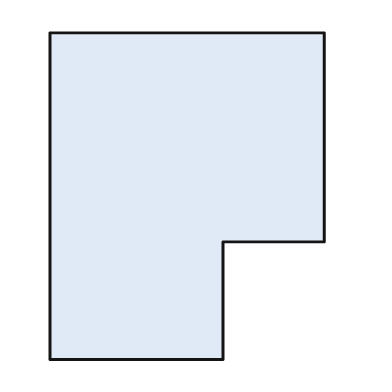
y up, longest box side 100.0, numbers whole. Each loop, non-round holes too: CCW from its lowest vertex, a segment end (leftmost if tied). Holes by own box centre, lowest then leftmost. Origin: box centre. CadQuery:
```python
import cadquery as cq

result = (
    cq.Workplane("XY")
    .moveTo(-42.0, -50.0)
    .lineTo(11.0, -50.0)
    .lineTo(11.0, -14.0)
    .lineTo(42.0, -14.0)
    .lineTo(42.0, 50.0)
    .lineTo(-42.0, 50.0)
    .close()
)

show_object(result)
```